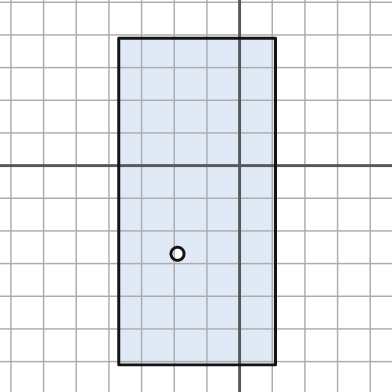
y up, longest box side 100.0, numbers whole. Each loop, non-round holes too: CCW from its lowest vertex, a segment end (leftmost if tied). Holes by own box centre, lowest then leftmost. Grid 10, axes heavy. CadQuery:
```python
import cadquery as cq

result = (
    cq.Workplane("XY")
    .moveTo(-37.0, -61.0)
    .lineTo(11.0, -61.0)
    .lineTo(11.0, 39.0)
    .lineTo(-37.0, 39.0)
    .close()
    .moveTo(-19.0, -27.0)
    .circle(2.0)
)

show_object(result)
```